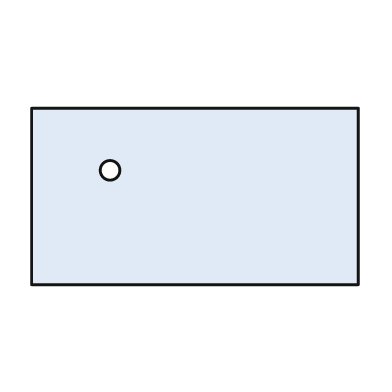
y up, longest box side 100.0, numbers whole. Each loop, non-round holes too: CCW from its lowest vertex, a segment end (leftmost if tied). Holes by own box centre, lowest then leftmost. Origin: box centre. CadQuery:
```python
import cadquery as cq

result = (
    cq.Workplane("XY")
    .moveTo(-50.0, -27.0)
    .lineTo(50.0, -27.0)
    .lineTo(50.0, 27.0)
    .lineTo(-50.0, 27.0)
    .close()
    .moveTo(-26.0, 8.0)
    .circle(3.0)
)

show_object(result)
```